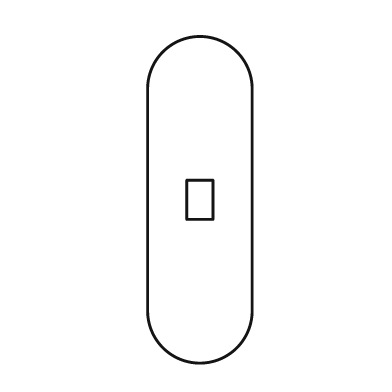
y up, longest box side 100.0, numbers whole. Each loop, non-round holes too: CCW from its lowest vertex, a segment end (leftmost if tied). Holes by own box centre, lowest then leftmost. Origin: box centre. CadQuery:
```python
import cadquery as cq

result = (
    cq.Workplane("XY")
    .moveTo(-16.0, -34.0)
    .threePointArc((0.0, -50.0), (16.0, -34.0))
    .lineTo(16.0, 34.0)
    .threePointArc((0.0, 50.0), (-16.0, 34.0))
    .close()
    .moveTo(-4.0, -6.0)
    .lineTo(4.0, -6.0)
    .lineTo(4.0, 6.0)
    .lineTo(-4.0, 6.0)
    .close()
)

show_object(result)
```